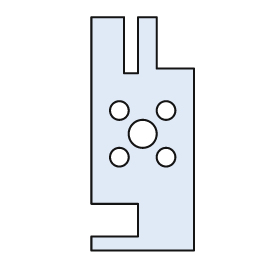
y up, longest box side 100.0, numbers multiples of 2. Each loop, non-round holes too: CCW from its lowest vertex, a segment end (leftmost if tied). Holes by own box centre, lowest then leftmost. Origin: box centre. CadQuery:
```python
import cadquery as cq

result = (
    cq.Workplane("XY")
    .moveTo(-22.0, -50.0)
    .lineTo(22.0, -50.0)
    .lineTo(22.0, 28.0)
    .lineTo(6.0, 28.0)
    .lineTo(6.0, 50.0)
    .lineTo(-2.0, 50.0)
    .lineTo(-2.0, 26.0)
    .lineTo(-8.0, 26.0)
    .lineTo(-8.0, 50.0)
    .lineTo(-22.0, 50.0)
    .lineTo(-22.0, -30.0)
    .lineTo(-2.0, -30.0)
    .lineTo(-2.0, -44.0)
    .lineTo(-22.0, -44.0)
    .close()
    .moveTo(-10.0, -10.0)
    .circle(4.0)
    .moveTo(10.0, -10.0)
    .circle(4.0)
    .moveTo(0.0, 0.0)
    .circle(6.0)
    .moveTo(-10.0, 10.0)
    .circle(4.0)
    .moveTo(10.0, 10.0)
    .circle(4.0)
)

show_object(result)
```